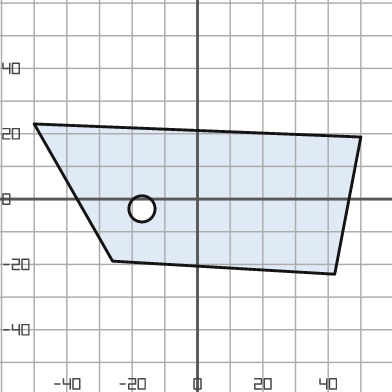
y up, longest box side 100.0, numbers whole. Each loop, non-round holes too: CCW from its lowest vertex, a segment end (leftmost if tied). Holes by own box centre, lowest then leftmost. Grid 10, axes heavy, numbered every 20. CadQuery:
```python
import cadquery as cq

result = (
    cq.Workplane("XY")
    .moveTo(42.0, -23.0)
    .lineTo(50.0, 19.0)
    .lineTo(-50.0, 23.0)
    .lineTo(-26.0, -19.0)
    .close()
    .moveTo(-17.0, -3.0)
    .circle(4.0)
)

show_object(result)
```